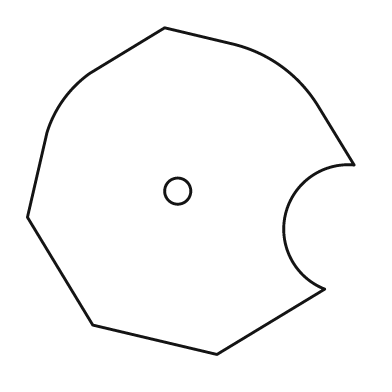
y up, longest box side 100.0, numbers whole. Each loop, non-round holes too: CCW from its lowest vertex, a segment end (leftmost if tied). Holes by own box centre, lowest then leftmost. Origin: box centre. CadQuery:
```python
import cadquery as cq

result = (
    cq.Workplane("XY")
    .moveTo(8.0, -50.0)
    .lineTo(41.0, -30.0)
    .threePointArc((29.0, -7.0), (50.0, 8.0))
    .lineTo(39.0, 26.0)
    .threePointArc((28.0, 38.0), (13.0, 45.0))
    .lineTo(-8.0, 50.0)
    .lineTo(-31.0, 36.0)
    .threePointArc((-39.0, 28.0), (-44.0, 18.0))
    .lineTo(-50.0, -8.0)
    .lineTo(-30.0, -41.0)
    .close()
    .moveTo(-4.0, 0.0)
    .circle(4.0)
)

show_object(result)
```